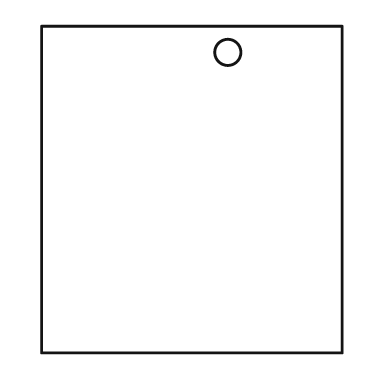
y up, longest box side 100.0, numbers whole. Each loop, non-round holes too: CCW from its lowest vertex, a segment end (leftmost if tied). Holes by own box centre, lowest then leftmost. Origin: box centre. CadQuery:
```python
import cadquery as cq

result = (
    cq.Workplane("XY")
    .moveTo(-46.0, -50.0)
    .lineTo(46.0, -50.0)
    .lineTo(46.0, 50.0)
    .lineTo(-46.0, 50.0)
    .close()
    .moveTo(11.0, 42.0)
    .circle(4.0)
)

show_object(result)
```